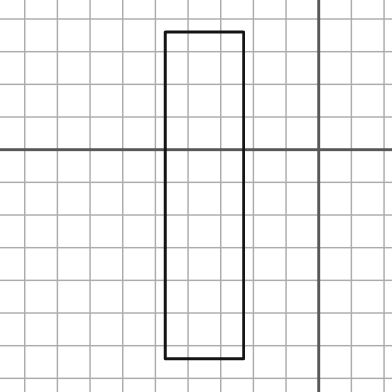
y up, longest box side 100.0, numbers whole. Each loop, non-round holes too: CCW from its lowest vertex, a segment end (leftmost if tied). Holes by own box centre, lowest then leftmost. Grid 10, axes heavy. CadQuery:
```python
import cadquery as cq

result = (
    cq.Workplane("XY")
    .moveTo(-47.0, -64.0)
    .lineTo(-23.0, -64.0)
    .lineTo(-23.0, 36.0)
    .lineTo(-47.0, 36.0)
    .close()
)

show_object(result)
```